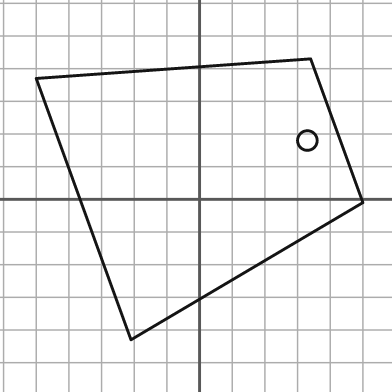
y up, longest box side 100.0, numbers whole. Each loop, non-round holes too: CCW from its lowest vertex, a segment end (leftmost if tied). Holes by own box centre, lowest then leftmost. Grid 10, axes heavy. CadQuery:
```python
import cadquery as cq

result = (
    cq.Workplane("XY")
    .moveTo(-21.0, -43.0)
    .lineTo(50.0, -1.0)
    .lineTo(34.0, 43.0)
    .lineTo(-50.0, 37.0)
    .close()
    .moveTo(33.0, 18.0)
    .circle(3.0)
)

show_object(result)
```